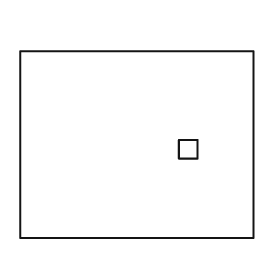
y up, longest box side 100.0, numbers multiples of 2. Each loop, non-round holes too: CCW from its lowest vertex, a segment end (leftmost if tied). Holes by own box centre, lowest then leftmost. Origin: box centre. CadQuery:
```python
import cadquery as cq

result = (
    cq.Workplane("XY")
    .moveTo(-50.0, -40.0)
    .lineTo(50.0, -40.0)
    .lineTo(50.0, 40.0)
    .lineTo(-50.0, 40.0)
    .close()
    .moveTo(18.0, -6.0)
    .lineTo(26.0, -6.0)
    .lineTo(26.0, 2.0)
    .lineTo(18.0, 2.0)
    .close()
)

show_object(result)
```